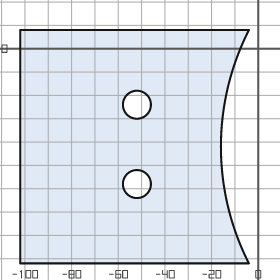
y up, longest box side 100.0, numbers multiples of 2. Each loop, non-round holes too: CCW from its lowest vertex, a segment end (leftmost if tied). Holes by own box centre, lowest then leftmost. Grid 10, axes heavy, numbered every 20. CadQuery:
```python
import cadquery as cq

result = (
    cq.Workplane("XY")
    .moveTo(-102.0, -92.0)
    .lineTo(-4.0, -92.0)
    .threePointArc((-16.0, -42.0), (-4.0, 8.0))
    .lineTo(-102.0, 8.0)
    .close()
    .moveTo(-52.0, -58.0)
    .circle(6.0)
    .moveTo(-52.0, -24.0)
    .circle(6.0)
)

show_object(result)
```